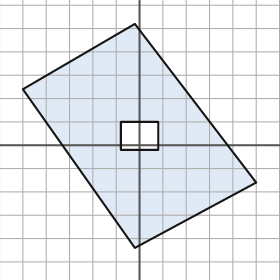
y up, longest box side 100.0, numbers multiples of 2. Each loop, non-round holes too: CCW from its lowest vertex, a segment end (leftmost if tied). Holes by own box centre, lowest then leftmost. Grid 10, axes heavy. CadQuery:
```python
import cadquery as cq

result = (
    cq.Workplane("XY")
    .moveTo(-2.0, -44.0)
    .lineTo(50.0, -16.0)
    .lineTo(-2.0, 52.0)
    .lineTo(-50.0, 24.0)
    .close()
    .moveTo(-8.0, -2.0)
    .lineTo(8.0, -2.0)
    .lineTo(8.0, 10.0)
    .lineTo(-8.0, 10.0)
    .close()
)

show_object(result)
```